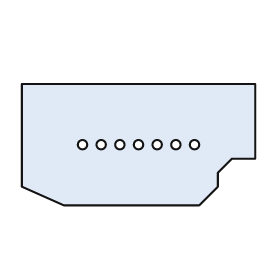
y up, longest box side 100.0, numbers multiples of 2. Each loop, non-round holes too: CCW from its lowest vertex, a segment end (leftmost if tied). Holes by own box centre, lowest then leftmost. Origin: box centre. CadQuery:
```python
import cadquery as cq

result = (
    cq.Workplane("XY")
    .moveTo(-32.0, -26.0)
    .lineTo(26.0, -26.0)
    .lineTo(34.0, -18.0)
    .lineTo(34.0, -12.0)
    .lineTo(40.0, -6.0)
    .lineTo(50.0, -6.0)
    .lineTo(50.0, 26.0)
    .lineTo(-50.0, 26.0)
    .lineTo(-50.0, -18.0)
    .close()
    .moveTo(-24.0, 0.0)
    .circle(2.0)
    .moveTo(-16.0, 0.0)
    .circle(2.0)
    .moveTo(-8.0, 0.0)
    .circle(2.0)
    .moveTo(0.0, 0.0)
    .circle(2.0)
    .moveTo(8.0, 0.0)
    .circle(2.0)
    .moveTo(16.0, 0.0)
    .circle(2.0)
    .moveTo(24.0, 0.0)
    .circle(2.0)
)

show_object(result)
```